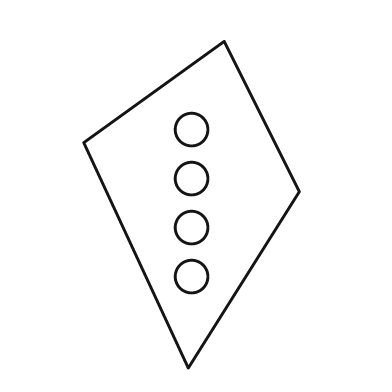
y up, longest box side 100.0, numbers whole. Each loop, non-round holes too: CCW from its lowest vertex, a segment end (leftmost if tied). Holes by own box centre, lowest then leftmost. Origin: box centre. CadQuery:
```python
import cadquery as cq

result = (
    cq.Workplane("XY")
    .moveTo(-1.0, -50.0)
    .lineTo(33.0, 4.0)
    .lineTo(10.0, 50.0)
    .lineTo(-33.0, 19.0)
    .close()
    .moveTo(0.0, -22.0)
    .circle(5.0)
    .moveTo(0.0, -7.0)
    .circle(5.0)
    .moveTo(0.0, 8.0)
    .circle(5.0)
    .moveTo(0.0, 23.0)
    .circle(5.0)
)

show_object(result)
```